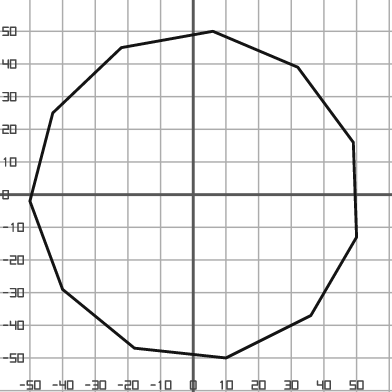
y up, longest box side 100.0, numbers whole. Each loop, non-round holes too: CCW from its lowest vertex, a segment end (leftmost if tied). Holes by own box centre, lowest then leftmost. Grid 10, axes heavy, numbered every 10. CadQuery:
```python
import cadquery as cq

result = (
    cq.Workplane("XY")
    .moveTo(10.0, -50.0)
    .lineTo(36.0, -37.0)
    .lineTo(50.0, -13.0)
    .lineTo(49.0, 16.0)
    .lineTo(32.0, 39.0)
    .lineTo(6.0, 50.0)
    .lineTo(-22.0, 45.0)
    .lineTo(-43.0, 25.0)
    .lineTo(-50.0, -2.0)
    .lineTo(-40.0, -29.0)
    .lineTo(-18.0, -47.0)
    .close()
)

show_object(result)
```